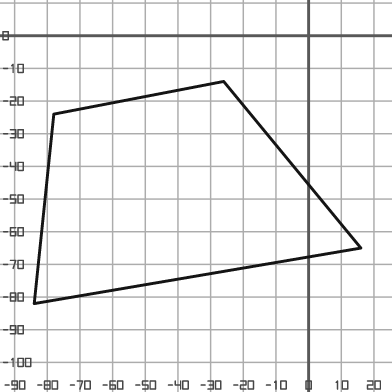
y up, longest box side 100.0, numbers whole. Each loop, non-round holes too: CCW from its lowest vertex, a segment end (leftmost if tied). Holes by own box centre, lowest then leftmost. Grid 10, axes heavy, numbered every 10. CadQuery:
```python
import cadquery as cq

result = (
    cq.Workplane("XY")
    .moveTo(-84.0, -82.0)
    .lineTo(16.0, -65.0)
    .lineTo(-26.0, -14.0)
    .lineTo(-78.0, -24.0)
    .close()
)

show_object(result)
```